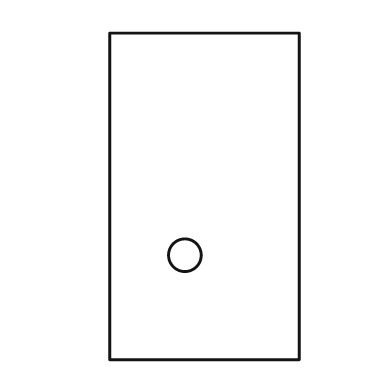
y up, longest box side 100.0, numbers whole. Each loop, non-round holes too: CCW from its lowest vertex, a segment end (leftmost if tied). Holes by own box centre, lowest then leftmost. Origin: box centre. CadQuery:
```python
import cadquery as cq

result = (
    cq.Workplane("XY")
    .moveTo(-29.0, -50.0)
    .lineTo(29.0, -50.0)
    .lineTo(29.0, 50.0)
    .lineTo(-29.0, 50.0)
    .close()
    .moveTo(-6.0, -18.0)
    .circle(5.0)
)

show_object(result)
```